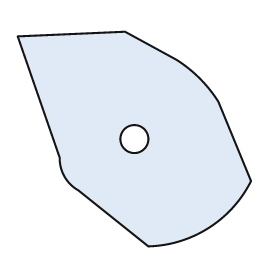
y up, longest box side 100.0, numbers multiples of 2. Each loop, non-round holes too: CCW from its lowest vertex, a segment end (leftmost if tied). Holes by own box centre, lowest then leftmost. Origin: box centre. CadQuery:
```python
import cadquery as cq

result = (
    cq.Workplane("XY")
    .moveTo(6.0, -46.0)
    .threePointArc((32.0, -38.0), (50.0, -18.0))
    .lineTo(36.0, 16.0)
    .threePointArc((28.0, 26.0), (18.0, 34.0))
    .lineTo(-4.0, 46.0)
    .lineTo(-50.0, 44.0)
    .lineTo(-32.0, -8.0)
    .threePointArc((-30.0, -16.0), (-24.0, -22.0))
    .close()
    .moveTo(0.0, 0.0)
    .circle(6.0)
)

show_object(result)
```